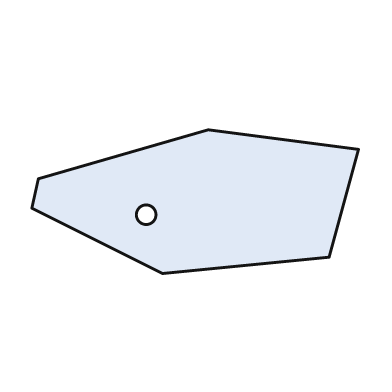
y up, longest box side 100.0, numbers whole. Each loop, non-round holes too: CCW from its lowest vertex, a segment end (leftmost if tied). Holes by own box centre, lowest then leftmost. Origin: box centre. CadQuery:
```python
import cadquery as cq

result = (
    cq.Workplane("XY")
    .moveTo(-10.0, -22.0)
    .lineTo(41.0, -17.0)
    .lineTo(50.0, 16.0)
    .lineTo(4.0, 22.0)
    .lineTo(-48.0, 7.0)
    .lineTo(-50.0, -2.0)
    .close()
    .moveTo(-15.0, -4.0)
    .circle(3.0)
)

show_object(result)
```